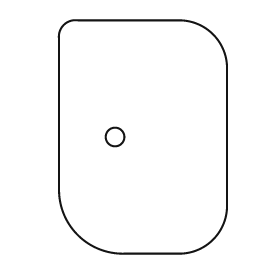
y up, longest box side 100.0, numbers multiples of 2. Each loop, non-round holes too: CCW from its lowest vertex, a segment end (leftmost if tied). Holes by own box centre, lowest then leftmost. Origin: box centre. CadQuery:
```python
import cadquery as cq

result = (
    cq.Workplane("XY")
    .moveTo(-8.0, -50.0)
    .lineTo(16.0, -50.0)
    .threePointArc((30.0, -44.0), (36.0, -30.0))
    .lineTo(36.0, 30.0)
    .threePointArc((30.0, 44.0), (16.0, 50.0))
    .lineTo(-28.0, 50.0)
    .threePointArc((-34.0, 48.0), (-36.0, 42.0))
    .lineTo(-36.0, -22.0)
    .threePointArc((-28.0, -42.0), (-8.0, -50.0))
    .close()
    .moveTo(-12.0, 0.0)
    .circle(4.0)
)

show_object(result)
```